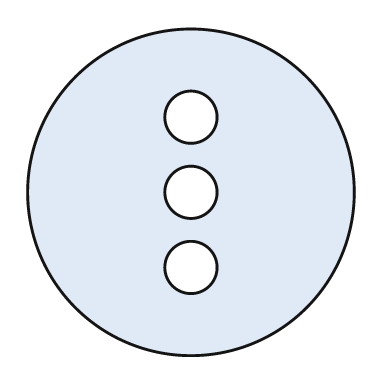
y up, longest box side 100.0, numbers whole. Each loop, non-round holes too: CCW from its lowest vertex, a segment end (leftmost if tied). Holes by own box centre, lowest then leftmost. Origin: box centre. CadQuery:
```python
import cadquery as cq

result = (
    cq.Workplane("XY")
    .moveTo(0.0, 0.0)
    .circle(50.0)
    .moveTo(0.0, -23.0)
    .circle(8.0)
    .moveTo(0.0, 0.0)
    .circle(8.0)
    .moveTo(0.0, 23.0)
    .circle(8.0)
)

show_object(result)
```